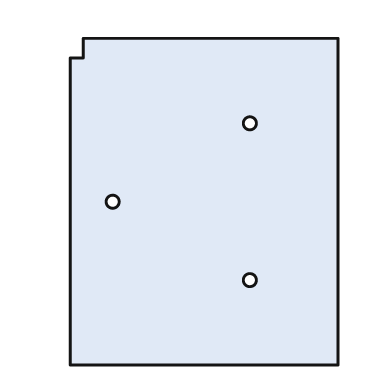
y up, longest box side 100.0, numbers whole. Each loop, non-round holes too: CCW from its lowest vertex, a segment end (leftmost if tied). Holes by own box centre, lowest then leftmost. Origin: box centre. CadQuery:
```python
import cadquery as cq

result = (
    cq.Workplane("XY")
    .moveTo(-41.0, -50.0)
    .lineTo(41.0, -50.0)
    .lineTo(41.0, 50.0)
    .lineTo(-37.0, 50.0)
    .lineTo(-37.0, 44.0)
    .lineTo(-41.0, 44.0)
    .close()
    .moveTo(14.0, -24.0)
    .circle(2.0)
    .moveTo(-28.0, 0.0)
    .circle(2.0)
    .moveTo(14.0, 24.0)
    .circle(2.0)
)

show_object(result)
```